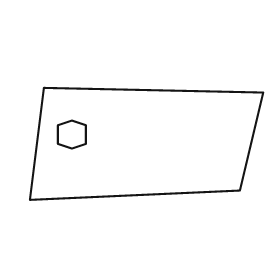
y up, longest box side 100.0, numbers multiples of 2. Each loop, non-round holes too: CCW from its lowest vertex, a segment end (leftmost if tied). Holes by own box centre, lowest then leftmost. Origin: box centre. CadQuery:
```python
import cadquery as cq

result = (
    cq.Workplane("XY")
    .moveTo(-50.0, -24.0)
    .lineTo(40.0, -20.0)
    .lineTo(50.0, 22.0)
    .lineTo(-44.0, 24.0)
    .close()
    .moveTo(-32.0, -2.0)
    .lineTo(-26.0, 0.0)
    .lineTo(-26.0, 8.0)
    .lineTo(-32.0, 10.0)
    .lineTo(-38.0, 8.0)
    .lineTo(-38.0, 0.0)
    .close()
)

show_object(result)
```